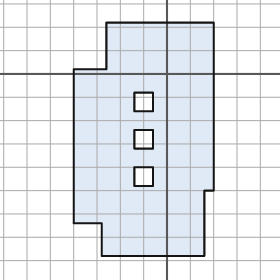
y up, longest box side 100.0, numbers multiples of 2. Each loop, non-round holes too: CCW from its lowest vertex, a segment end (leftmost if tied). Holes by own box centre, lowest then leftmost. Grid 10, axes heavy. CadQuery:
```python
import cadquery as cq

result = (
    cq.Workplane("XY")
    .moveTo(-28.0, -78.0)
    .lineTo(16.0, -78.0)
    .lineTo(16.0, -50.0)
    .lineTo(20.0, -50.0)
    .lineTo(20.0, 22.0)
    .lineTo(-26.0, 22.0)
    .lineTo(-26.0, 2.0)
    .lineTo(-40.0, 2.0)
    .lineTo(-40.0, -64.0)
    .lineTo(-28.0, -64.0)
    .close()
    .moveTo(-14.0, -48.0)
    .lineTo(-6.0, -48.0)
    .lineTo(-6.0, -40.0)
    .lineTo(-14.0, -40.0)
    .close()
    .moveTo(-14.0, -32.0)
    .lineTo(-6.0, -32.0)
    .lineTo(-6.0, -24.0)
    .lineTo(-14.0, -24.0)
    .close()
    .moveTo(-14.0, -16.0)
    .lineTo(-6.0, -16.0)
    .lineTo(-6.0, -8.0)
    .lineTo(-14.0, -8.0)
    .close()
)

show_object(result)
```